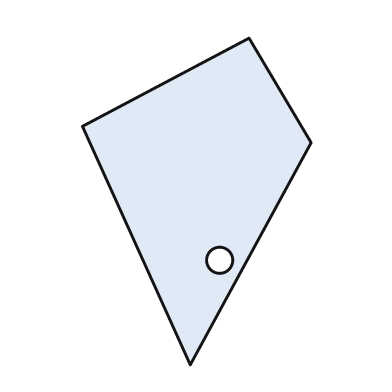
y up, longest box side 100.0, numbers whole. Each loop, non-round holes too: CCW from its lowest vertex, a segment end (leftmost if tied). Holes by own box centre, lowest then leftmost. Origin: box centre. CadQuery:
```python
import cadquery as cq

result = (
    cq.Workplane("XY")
    .moveTo(-2.0, -50.0)
    .lineTo(35.0, 18.0)
    .lineTo(16.0, 50.0)
    .lineTo(-35.0, 23.0)
    .close()
    .moveTo(7.0, -18.0)
    .circle(4.0)
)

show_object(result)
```